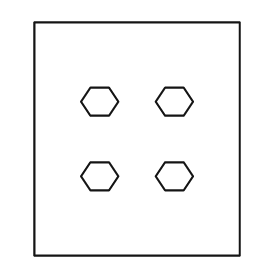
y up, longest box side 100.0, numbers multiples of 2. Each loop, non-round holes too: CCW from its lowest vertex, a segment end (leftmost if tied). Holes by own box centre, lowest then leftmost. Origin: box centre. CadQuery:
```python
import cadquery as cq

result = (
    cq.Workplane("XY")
    .moveTo(-44.0, -50.0)
    .lineTo(44.0, -50.0)
    .lineTo(44.0, 50.0)
    .lineTo(-44.0, 50.0)
    .close()
    .moveTo(-20.0, -22.0)
    .lineTo(-12.0, -22.0)
    .lineTo(-8.0, -16.0)
    .lineTo(-12.0, -10.0)
    .lineTo(-20.0, -10.0)
    .lineTo(-24.0, -16.0)
    .close()
    .moveTo(12.0, -22.0)
    .lineTo(20.0, -22.0)
    .lineTo(24.0, -16.0)
    .lineTo(20.0, -10.0)
    .lineTo(12.0, -10.0)
    .lineTo(8.0, -16.0)
    .close()
    .moveTo(-20.0, 10.0)
    .lineTo(-12.0, 10.0)
    .lineTo(-8.0, 16.0)
    .lineTo(-12.0, 22.0)
    .lineTo(-20.0, 22.0)
    .lineTo(-24.0, 16.0)
    .close()
    .moveTo(12.0, 10.0)
    .lineTo(20.0, 10.0)
    .lineTo(24.0, 16.0)
    .lineTo(20.0, 22.0)
    .lineTo(12.0, 22.0)
    .lineTo(8.0, 16.0)
    .close()
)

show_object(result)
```